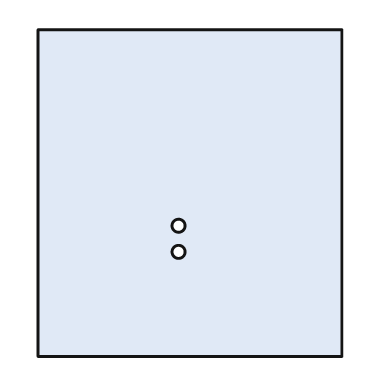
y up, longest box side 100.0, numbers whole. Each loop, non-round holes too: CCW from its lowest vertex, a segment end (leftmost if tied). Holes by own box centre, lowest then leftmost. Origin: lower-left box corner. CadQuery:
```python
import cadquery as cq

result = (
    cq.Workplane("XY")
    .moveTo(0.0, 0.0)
    .lineTo(93.0, 0.0)
    .lineTo(93.0, 100.0)
    .lineTo(0.0, 100.0)
    .close()
    .moveTo(43.0, 32.0)
    .circle(2.0)
    .moveTo(43.0, 40.0)
    .circle(2.0)
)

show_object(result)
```